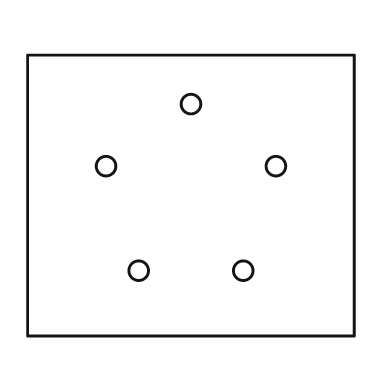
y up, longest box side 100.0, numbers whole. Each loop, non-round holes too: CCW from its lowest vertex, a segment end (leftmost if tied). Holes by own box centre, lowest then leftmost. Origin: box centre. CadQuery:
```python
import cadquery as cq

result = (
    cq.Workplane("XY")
    .moveTo(-50.0, -43.0)
    .lineTo(50.0, -43.0)
    .lineTo(50.0, 43.0)
    .lineTo(-50.0, 43.0)
    .close()
    .moveTo(-16.0, -23.0)
    .circle(3.0)
    .moveTo(16.0, -23.0)
    .circle(3.0)
    .moveTo(-26.0, 9.0)
    .circle(3.0)
    .moveTo(26.0, 9.0)
    .circle(3.0)
    .moveTo(0.0, 28.0)
    .circle(3.0)
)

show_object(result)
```